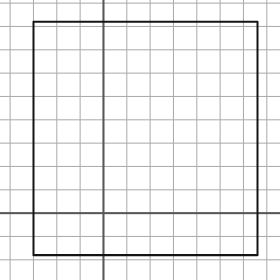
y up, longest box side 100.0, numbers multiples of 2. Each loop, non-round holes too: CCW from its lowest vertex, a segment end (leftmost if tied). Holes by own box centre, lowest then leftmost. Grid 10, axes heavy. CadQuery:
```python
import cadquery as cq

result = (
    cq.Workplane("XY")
    .moveTo(-30.0, -18.0)
    .lineTo(66.0, -18.0)
    .lineTo(66.0, 82.0)
    .lineTo(-30.0, 82.0)
    .close()
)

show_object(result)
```